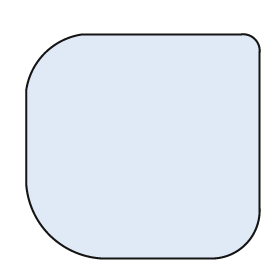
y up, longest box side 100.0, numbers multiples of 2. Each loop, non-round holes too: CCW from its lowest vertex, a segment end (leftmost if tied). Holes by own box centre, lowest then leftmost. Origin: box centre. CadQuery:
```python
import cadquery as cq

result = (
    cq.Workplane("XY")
    .moveTo(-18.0, -48.0)
    .lineTo(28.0, -48.0)
    .threePointArc((44.0, -42.0), (50.0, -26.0))
    .lineTo(50.0, 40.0)
    .threePointArc((48.0, 46.0), (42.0, 48.0))
    .lineTo(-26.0, 48.0)
    .threePointArc((-42.0, 40.0), (-50.0, 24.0))
    .lineTo(-50.0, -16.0)
    .threePointArc((-40.0, -38.0), (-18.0, -48.0))
    .close()
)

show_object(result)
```